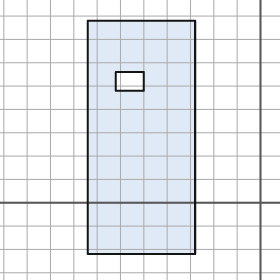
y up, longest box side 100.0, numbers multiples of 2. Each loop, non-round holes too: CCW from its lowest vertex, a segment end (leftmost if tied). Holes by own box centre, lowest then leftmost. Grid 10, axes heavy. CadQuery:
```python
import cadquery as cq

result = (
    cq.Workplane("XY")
    .moveTo(-74.0, -22.0)
    .lineTo(-28.0, -22.0)
    .lineTo(-28.0, 78.0)
    .lineTo(-74.0, 78.0)
    .close()
    .moveTo(-62.0, 48.0)
    .lineTo(-50.0, 48.0)
    .lineTo(-50.0, 56.0)
    .lineTo(-62.0, 56.0)
    .close()
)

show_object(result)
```